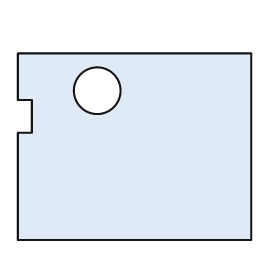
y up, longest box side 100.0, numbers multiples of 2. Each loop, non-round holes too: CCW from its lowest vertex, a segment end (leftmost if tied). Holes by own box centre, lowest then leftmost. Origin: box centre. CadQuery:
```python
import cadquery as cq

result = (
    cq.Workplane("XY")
    .moveTo(-50.0, -40.0)
    .lineTo(50.0, -40.0)
    .lineTo(50.0, 40.0)
    .lineTo(-50.0, 40.0)
    .lineTo(-50.0, 20.0)
    .lineTo(-44.0, 20.0)
    .lineTo(-44.0, 6.0)
    .lineTo(-50.0, 6.0)
    .close()
    .moveTo(-16.0, 24.0)
    .circle(10.0)
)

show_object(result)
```